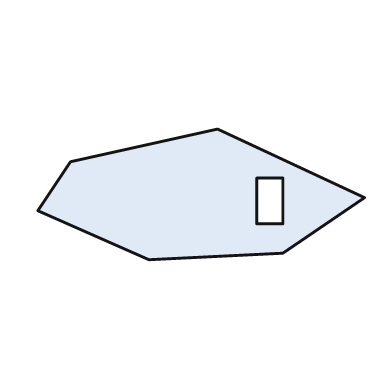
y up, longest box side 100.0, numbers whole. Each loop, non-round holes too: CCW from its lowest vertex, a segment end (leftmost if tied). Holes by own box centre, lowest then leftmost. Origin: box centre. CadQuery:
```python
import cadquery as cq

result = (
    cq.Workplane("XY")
    .moveTo(-16.0, -20.0)
    .lineTo(25.0, -18.0)
    .lineTo(50.0, -1.0)
    .lineTo(5.0, 20.0)
    .lineTo(-40.0, 10.0)
    .lineTo(-50.0, -5.0)
    .close()
    .moveTo(17.0, -9.0)
    .lineTo(25.0, -9.0)
    .lineTo(25.0, 5.0)
    .lineTo(17.0, 5.0)
    .close()
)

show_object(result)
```